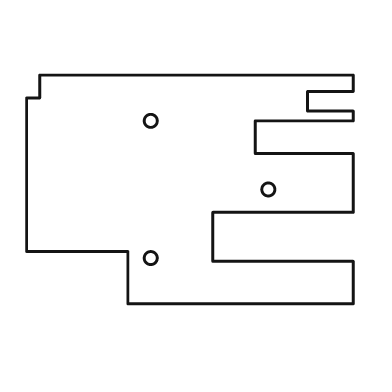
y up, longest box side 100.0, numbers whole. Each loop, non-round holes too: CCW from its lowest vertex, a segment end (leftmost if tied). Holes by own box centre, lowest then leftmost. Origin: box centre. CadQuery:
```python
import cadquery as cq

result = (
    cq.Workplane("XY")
    .moveTo(-19.0, -35.0)
    .lineTo(50.0, -35.0)
    .lineTo(50.0, -22.0)
    .lineTo(7.0, -22.0)
    .lineTo(7.0, -7.0)
    .lineTo(50.0, -7.0)
    .lineTo(50.0, 11.0)
    .lineTo(20.0, 11.0)
    .lineTo(20.0, 21.0)
    .lineTo(50.0, 21.0)
    .lineTo(50.0, 24.0)
    .lineTo(36.0, 24.0)
    .lineTo(36.0, 30.0)
    .lineTo(50.0, 30.0)
    .lineTo(50.0, 35.0)
    .lineTo(-46.0, 35.0)
    .lineTo(-46.0, 28.0)
    .lineTo(-50.0, 28.0)
    .lineTo(-50.0, -19.0)
    .lineTo(-19.0, -19.0)
    .close()
    .moveTo(-12.0, -21.0)
    .circle(2.0)
    .moveTo(24.0, 0.0)
    .circle(2.0)
    .moveTo(-12.0, 21.0)
    .circle(2.0)
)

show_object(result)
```